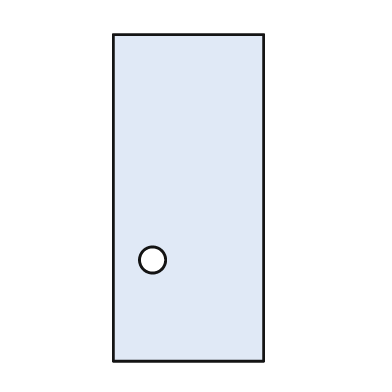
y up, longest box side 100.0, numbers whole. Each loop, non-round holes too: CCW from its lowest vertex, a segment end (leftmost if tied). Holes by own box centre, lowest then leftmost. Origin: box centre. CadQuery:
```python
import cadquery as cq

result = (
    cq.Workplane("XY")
    .moveTo(-23.0, -50.0)
    .lineTo(23.0, -50.0)
    .lineTo(23.0, 50.0)
    .lineTo(-23.0, 50.0)
    .close()
    .moveTo(-11.0, -19.0)
    .circle(4.0)
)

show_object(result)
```